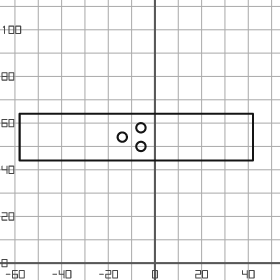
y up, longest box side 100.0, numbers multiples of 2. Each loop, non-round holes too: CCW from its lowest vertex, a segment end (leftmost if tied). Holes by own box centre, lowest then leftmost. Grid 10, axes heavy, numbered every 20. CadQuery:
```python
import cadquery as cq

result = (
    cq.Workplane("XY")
    .moveTo(-58.0, 44.0)
    .lineTo(42.0, 44.0)
    .lineTo(42.0, 64.0)
    .lineTo(-58.0, 64.0)
    .close()
    .moveTo(-6.0, 50.0)
    .circle(2.0)
    .moveTo(-14.0, 54.0)
    .circle(2.0)
    .moveTo(-6.0, 58.0)
    .circle(2.0)
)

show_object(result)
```